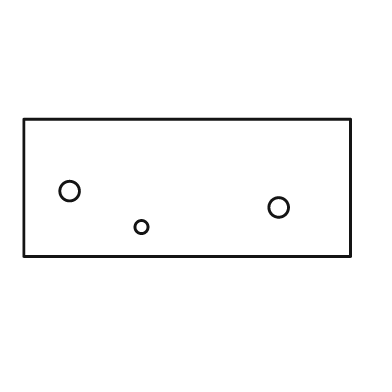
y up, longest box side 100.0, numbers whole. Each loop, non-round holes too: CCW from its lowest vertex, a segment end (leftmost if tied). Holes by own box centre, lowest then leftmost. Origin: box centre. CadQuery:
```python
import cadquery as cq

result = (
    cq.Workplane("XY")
    .moveTo(-50.0, -21.0)
    .lineTo(50.0, -21.0)
    .lineTo(50.0, 21.0)
    .lineTo(-50.0, 21.0)
    .close()
    .moveTo(-14.0, -12.0)
    .circle(2.0)
    .moveTo(28.0, -6.0)
    .circle(3.0)
    .moveTo(-36.0, -1.0)
    .circle(3.0)
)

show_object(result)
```